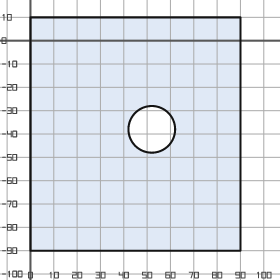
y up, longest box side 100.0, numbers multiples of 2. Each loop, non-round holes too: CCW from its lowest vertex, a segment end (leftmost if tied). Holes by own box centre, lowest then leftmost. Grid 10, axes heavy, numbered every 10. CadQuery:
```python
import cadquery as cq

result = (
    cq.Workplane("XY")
    .moveTo(0.0, -90.0)
    .lineTo(90.0, -90.0)
    .lineTo(90.0, 10.0)
    .lineTo(0.0, 10.0)
    .close()
    .moveTo(52.0, -38.0)
    .circle(10.0)
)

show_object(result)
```